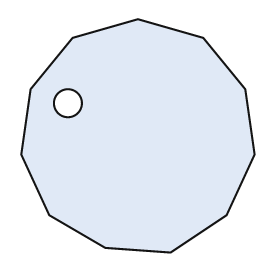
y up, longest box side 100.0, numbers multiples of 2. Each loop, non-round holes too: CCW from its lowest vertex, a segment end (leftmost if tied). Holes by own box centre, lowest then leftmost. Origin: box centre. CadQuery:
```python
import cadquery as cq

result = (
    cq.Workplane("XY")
    .moveTo(14.0, -50.0)
    .lineTo(38.0, -34.0)
    .lineTo(50.0, -8.0)
    .lineTo(46.0, 20.0)
    .lineTo(28.0, 42.0)
    .lineTo(0.0, 50.0)
    .lineTo(-28.0, 42.0)
    .lineTo(-46.0, 20.0)
    .lineTo(-50.0, -8.0)
    .lineTo(-38.0, -34.0)
    .lineTo(-14.0, -48.0)
    .close()
    .moveTo(-30.0, 14.0)
    .circle(6.0)
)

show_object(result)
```